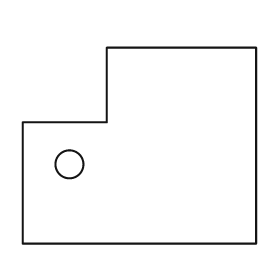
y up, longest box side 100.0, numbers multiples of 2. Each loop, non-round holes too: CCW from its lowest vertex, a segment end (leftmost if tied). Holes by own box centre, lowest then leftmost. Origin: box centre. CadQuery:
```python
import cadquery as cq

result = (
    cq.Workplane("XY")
    .moveTo(-50.0, -42.0)
    .lineTo(50.0, -42.0)
    .lineTo(50.0, 42.0)
    .lineTo(-14.0, 42.0)
    .lineTo(-14.0, 10.0)
    .lineTo(-50.0, 10.0)
    .close()
    .moveTo(-30.0, -8.0)
    .circle(6.0)
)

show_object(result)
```